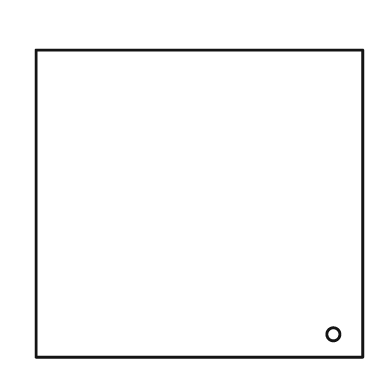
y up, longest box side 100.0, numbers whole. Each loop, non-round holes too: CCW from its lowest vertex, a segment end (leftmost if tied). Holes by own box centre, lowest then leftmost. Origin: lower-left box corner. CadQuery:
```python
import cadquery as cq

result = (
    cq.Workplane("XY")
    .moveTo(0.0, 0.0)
    .lineTo(100.0, 0.0)
    .lineTo(100.0, 94.0)
    .lineTo(0.0, 94.0)
    .close()
    .moveTo(91.0, 7.0)
    .circle(2.0)
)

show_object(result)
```